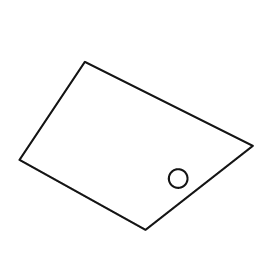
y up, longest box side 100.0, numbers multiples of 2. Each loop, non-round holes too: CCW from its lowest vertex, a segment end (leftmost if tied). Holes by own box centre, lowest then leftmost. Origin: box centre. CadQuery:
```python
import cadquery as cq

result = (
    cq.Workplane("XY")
    .moveTo(4.0, -36.0)
    .lineTo(50.0, 0.0)
    .lineTo(-22.0, 36.0)
    .lineTo(-50.0, -6.0)
    .close()
    .moveTo(18.0, -14.0)
    .circle(4.0)
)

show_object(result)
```